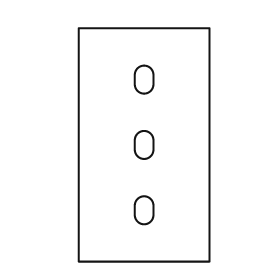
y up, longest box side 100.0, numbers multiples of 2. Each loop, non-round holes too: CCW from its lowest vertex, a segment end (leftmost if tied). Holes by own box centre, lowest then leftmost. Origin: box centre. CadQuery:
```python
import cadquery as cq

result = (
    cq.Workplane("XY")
    .moveTo(-28.0, -50.0)
    .lineTo(28.0, -50.0)
    .lineTo(28.0, 50.0)
    .lineTo(-28.0, 50.0)
    .close()
    .moveTo(-4.0, -30.0)
    .threePointArc((0.0, -34.0), (4.0, -30.0))
    .lineTo(4.0, -26.0)
    .threePointArc((0.0, -22.0), (-4.0, -26.0))
    .close()
    .moveTo(-4.0, -2.0)
    .threePointArc((0.0, -6.0), (4.0, -2.0))
    .lineTo(4.0, 2.0)
    .threePointArc((0.0, 6.0), (-4.0, 2.0))
    .close()
    .moveTo(-4.0, 26.0)
    .threePointArc((0.0, 22.0), (4.0, 26.0))
    .lineTo(4.0, 30.0)
    .threePointArc((0.0, 34.0), (-4.0, 30.0))
    .close()
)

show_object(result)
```